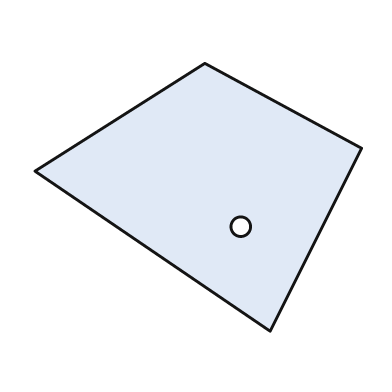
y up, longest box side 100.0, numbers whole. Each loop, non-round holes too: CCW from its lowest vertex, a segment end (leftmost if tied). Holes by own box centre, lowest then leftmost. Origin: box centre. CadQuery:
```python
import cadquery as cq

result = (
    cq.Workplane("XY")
    .moveTo(22.0, -41.0)
    .lineTo(50.0, 15.0)
    .lineTo(2.0, 41.0)
    .lineTo(-50.0, 8.0)
    .close()
    .moveTo(13.0, -9.0)
    .circle(3.0)
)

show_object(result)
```